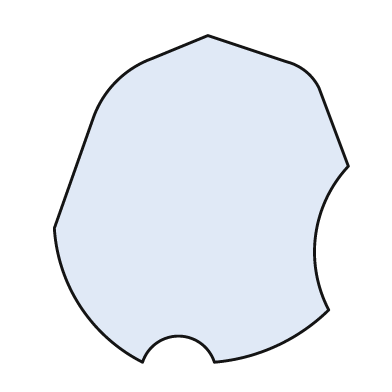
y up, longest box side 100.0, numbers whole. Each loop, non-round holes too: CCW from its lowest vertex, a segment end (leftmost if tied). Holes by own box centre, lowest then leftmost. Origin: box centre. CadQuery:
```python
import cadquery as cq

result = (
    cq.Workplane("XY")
    .moveTo(-18.0, -50.0)
    .threePointArc((-7.0, -42.0), (4.0, -50.0))
    .threePointArc((23.0, -45.0), (39.0, -34.0))
    .threePointArc((35.0, -11.0), (45.0, 10.0))
    .lineTo(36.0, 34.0)
    .threePointArc((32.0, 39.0), (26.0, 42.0))
    .lineTo(2.0, 50.0)
    .lineTo(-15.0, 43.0)
    .threePointArc((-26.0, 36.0), (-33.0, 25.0))
    .lineTo(-45.0, -9.0)
    .threePointArc((-37.0, -33.0), (-18.0, -50.0))
    .close()
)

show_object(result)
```